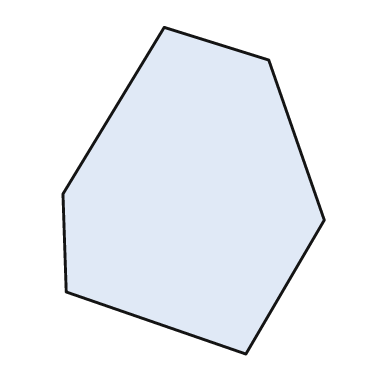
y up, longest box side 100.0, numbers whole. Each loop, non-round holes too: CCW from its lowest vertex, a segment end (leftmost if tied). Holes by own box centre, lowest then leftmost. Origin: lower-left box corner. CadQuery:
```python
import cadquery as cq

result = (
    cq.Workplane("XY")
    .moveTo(56.0, 0.0)
    .lineTo(80.0, 41.0)
    .lineTo(63.0, 90.0)
    .lineTo(31.0, 100.0)
    .lineTo(0.0, 49.0)
    .lineTo(1.0, 19.0)
    .close()
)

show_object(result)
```